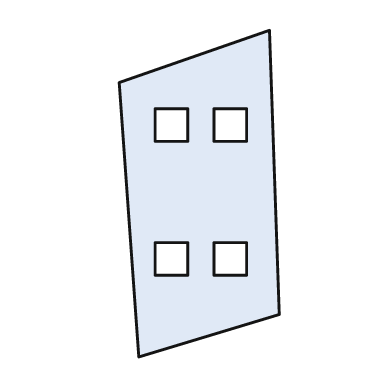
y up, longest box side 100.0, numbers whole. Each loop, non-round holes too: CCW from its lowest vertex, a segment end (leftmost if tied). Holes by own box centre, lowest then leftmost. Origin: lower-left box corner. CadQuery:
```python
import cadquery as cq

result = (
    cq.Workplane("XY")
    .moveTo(6.0, 0.0)
    .lineTo(49.0, 13.0)
    .lineTo(46.0, 100.0)
    .lineTo(0.0, 84.0)
    .close()
    .moveTo(11.0, 25.0)
    .lineTo(21.0, 25.0)
    .lineTo(21.0, 35.0)
    .lineTo(11.0, 35.0)
    .close()
    .moveTo(29.0, 25.0)
    .lineTo(39.0, 25.0)
    .lineTo(39.0, 35.0)
    .lineTo(29.0, 35.0)
    .close()
    .moveTo(11.0, 66.0)
    .lineTo(21.0, 66.0)
    .lineTo(21.0, 76.0)
    .lineTo(11.0, 76.0)
    .close()
    .moveTo(29.0, 66.0)
    .lineTo(39.0, 66.0)
    .lineTo(39.0, 76.0)
    .lineTo(29.0, 76.0)
    .close()
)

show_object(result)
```